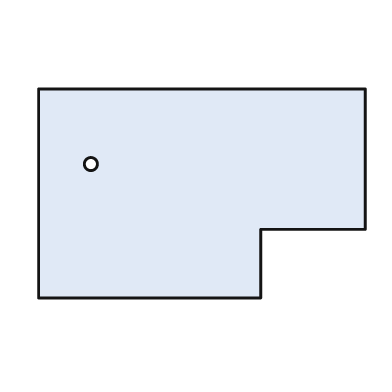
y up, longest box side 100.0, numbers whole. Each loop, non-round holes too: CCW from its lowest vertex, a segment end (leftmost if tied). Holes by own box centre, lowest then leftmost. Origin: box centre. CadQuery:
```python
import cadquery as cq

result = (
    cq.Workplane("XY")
    .moveTo(-50.0, -32.0)
    .lineTo(18.0, -32.0)
    .lineTo(18.0, -11.0)
    .lineTo(50.0, -11.0)
    .lineTo(50.0, 32.0)
    .lineTo(-50.0, 32.0)
    .close()
    .moveTo(-34.0, 9.0)
    .circle(2.0)
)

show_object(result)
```